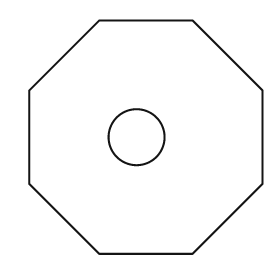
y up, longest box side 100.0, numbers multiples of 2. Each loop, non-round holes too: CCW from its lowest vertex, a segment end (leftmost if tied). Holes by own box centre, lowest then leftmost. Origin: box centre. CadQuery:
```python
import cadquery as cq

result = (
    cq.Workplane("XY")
    .moveTo(-20.0, -50.0)
    .lineTo(20.0, -50.0)
    .lineTo(50.0, -20.0)
    .lineTo(50.0, 20.0)
    .lineTo(20.0, 50.0)
    .lineTo(-20.0, 50.0)
    .lineTo(-50.0, 20.0)
    .lineTo(-50.0, -20.0)
    .close()
    .moveTo(-4.0, 0.0)
    .circle(12.0)
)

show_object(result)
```